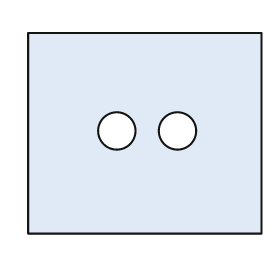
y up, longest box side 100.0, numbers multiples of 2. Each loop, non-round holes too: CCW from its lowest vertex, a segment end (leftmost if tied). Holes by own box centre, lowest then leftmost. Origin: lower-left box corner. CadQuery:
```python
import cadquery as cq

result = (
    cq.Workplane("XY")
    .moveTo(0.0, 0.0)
    .lineTo(100.0, 0.0)
    .lineTo(100.0, 86.0)
    .lineTo(0.0, 86.0)
    .close()
    .moveTo(38.0, 44.0)
    .circle(8.0)
    .moveTo(64.0, 44.0)
    .circle(8.0)
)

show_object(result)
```